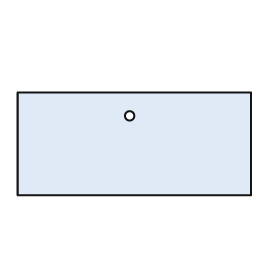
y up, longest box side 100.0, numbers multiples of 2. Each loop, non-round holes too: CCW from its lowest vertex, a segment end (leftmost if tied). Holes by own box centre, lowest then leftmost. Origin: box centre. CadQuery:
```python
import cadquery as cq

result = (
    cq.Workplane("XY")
    .moveTo(-50.0, -22.0)
    .lineTo(50.0, -22.0)
    .lineTo(50.0, 22.0)
    .lineTo(-50.0, 22.0)
    .close()
    .moveTo(-2.0, 12.0)
    .circle(2.0)
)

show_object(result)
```